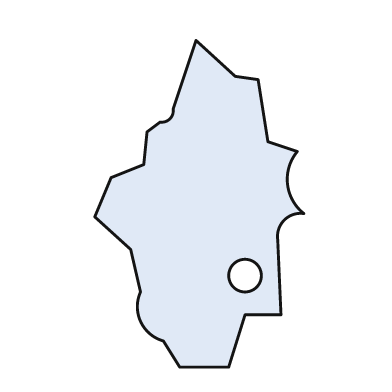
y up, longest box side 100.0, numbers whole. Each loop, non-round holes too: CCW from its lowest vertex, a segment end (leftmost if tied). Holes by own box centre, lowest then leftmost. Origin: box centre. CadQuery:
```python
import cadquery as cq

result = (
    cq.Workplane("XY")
    .moveTo(-6.0, -50.0)
    .lineTo(9.0, -50.0)
    .lineTo(14.0, -34.0)
    .lineTo(25.0, -34.0)
    .lineTo(24.0, -11.0)
    .threePointArc((26.0, -5.0), (32.0, -3.0))
    .threePointArc((27.0, 6.0), (30.0, 16.0))
    .lineTo(21.0, 19.0)
    .lineTo(18.0, 38.0)
    .lineTo(11.0, 39.0)
    .lineTo(-1.0, 50.0)
    .lineTo(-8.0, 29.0)
    .threePointArc((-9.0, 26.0), (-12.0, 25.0))
    .lineTo(-16.0, 22.0)
    .lineTo(-17.0, 12.0)
    .lineTo(-27.0, 8.0)
    .lineTo(-32.0, -4.0)
    .lineTo(-21.0, -14.0)
    .lineTo(-18.0, -27.0)
    .threePointArc((-18.0, -36.0), (-11.0, -42.0))
    .close()
    .moveTo(14.0, -22.0)
    .circle(5.0)
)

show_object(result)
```